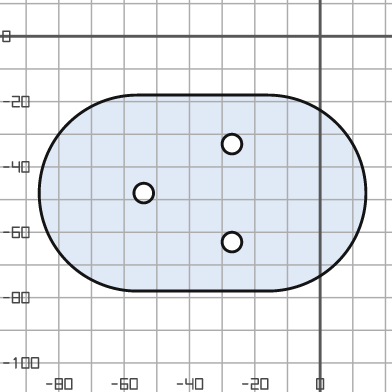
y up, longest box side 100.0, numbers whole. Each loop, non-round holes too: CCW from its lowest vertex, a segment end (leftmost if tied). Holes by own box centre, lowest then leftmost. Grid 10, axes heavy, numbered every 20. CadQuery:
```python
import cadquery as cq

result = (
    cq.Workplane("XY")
    .moveTo(-56.0, -78.0)
    .lineTo(-16.0, -78.0)
    .threePointArc((14.0, -48.0), (-16.0, -18.0))
    .lineTo(-56.0, -18.0)
    .threePointArc((-86.0, -48.0), (-56.0, -78.0))
    .close()
    .moveTo(-27.0, -63.0)
    .circle(3.0)
    .moveTo(-54.0, -48.0)
    .circle(3.0)
    .moveTo(-27.0, -33.0)
    .circle(3.0)
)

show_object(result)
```